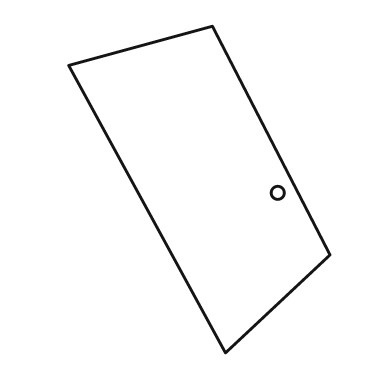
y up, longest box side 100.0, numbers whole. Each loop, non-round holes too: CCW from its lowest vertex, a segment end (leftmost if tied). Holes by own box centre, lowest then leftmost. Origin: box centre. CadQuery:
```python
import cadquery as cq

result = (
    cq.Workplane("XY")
    .moveTo(8.0, -50.0)
    .lineTo(40.0, -20.0)
    .lineTo(4.0, 50.0)
    .lineTo(-40.0, 38.0)
    .close()
    .moveTo(24.0, -1.0)
    .circle(2.0)
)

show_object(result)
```